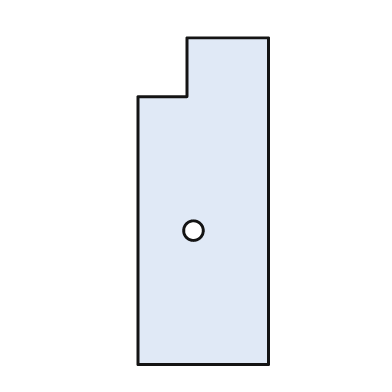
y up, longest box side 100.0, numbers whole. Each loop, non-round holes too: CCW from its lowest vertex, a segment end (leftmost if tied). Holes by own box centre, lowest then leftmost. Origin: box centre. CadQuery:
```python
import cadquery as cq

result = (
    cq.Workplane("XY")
    .moveTo(-20.0, -50.0)
    .lineTo(20.0, -50.0)
    .lineTo(20.0, 50.0)
    .lineTo(-5.0, 50.0)
    .lineTo(-5.0, 32.0)
    .lineTo(-20.0, 32.0)
    .close()
    .moveTo(-3.0, -9.0)
    .circle(3.0)
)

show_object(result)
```